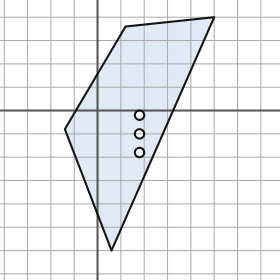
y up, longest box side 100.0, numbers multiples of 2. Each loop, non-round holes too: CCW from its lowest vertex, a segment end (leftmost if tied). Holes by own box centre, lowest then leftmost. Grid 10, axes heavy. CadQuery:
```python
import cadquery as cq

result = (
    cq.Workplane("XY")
    .moveTo(6.0, -60.0)
    .lineTo(50.0, 40.0)
    .lineTo(12.0, 36.0)
    .lineTo(-14.0, -8.0)
    .close()
    .moveTo(18.0, -18.0)
    .circle(2.0)
    .moveTo(18.0, -10.0)
    .circle(2.0)
    .moveTo(18.0, -2.0)
    .circle(2.0)
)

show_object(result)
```